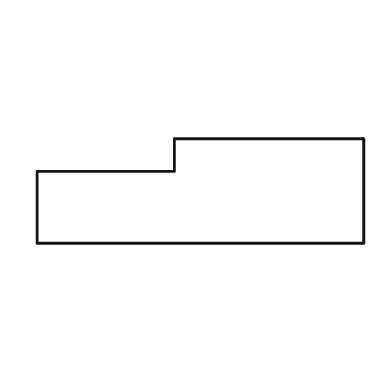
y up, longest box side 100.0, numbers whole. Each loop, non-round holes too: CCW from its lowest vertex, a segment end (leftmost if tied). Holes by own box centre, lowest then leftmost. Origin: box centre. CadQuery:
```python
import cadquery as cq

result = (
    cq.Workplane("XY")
    .moveTo(-50.0, -16.0)
    .lineTo(50.0, -16.0)
    .lineTo(50.0, 16.0)
    .lineTo(-8.0, 16.0)
    .lineTo(-8.0, 6.0)
    .lineTo(-50.0, 6.0)
    .close()
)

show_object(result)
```